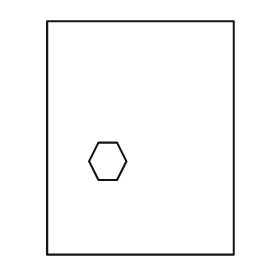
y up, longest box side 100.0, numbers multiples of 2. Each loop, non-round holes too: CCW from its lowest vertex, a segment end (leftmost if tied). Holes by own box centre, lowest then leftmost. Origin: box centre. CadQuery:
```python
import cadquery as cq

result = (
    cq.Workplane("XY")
    .moveTo(-40.0, -50.0)
    .lineTo(40.0, -50.0)
    .lineTo(40.0, 50.0)
    .lineTo(-40.0, 50.0)
    .close()
    .moveTo(-18.0, -18.0)
    .lineTo(-10.0, -18.0)
    .lineTo(-6.0, -10.0)
    .lineTo(-10.0, -2.0)
    .lineTo(-18.0, -2.0)
    .lineTo(-22.0, -10.0)
    .close()
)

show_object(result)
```